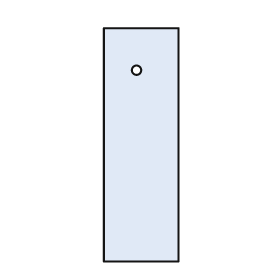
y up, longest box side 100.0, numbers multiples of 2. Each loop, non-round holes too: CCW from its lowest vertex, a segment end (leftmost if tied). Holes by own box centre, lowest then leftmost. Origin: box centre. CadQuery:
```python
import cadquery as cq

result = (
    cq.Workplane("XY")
    .moveTo(-16.0, -50.0)
    .lineTo(16.0, -50.0)
    .lineTo(16.0, 50.0)
    .lineTo(-16.0, 50.0)
    .close()
    .moveTo(-2.0, 32.0)
    .circle(2.0)
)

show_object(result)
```